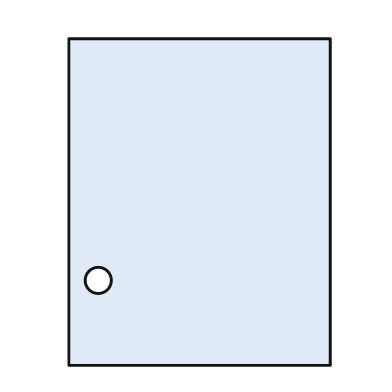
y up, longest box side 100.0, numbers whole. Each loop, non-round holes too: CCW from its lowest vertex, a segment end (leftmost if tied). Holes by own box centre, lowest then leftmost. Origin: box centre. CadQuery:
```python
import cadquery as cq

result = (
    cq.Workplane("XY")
    .moveTo(-40.0, -50.0)
    .lineTo(40.0, -50.0)
    .lineTo(40.0, 50.0)
    .lineTo(-40.0, 50.0)
    .close()
    .moveTo(-31.0, -24.0)
    .circle(4.0)
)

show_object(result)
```